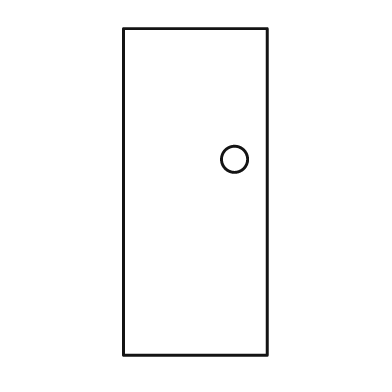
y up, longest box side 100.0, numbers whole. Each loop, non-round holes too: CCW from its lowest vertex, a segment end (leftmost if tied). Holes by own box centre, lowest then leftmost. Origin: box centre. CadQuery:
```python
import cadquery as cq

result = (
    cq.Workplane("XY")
    .moveTo(-22.0, -50.0)
    .lineTo(22.0, -50.0)
    .lineTo(22.0, 50.0)
    .lineTo(-22.0, 50.0)
    .close()
    .moveTo(12.0, 10.0)
    .circle(4.0)
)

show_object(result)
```